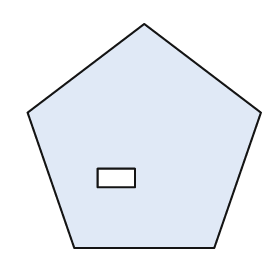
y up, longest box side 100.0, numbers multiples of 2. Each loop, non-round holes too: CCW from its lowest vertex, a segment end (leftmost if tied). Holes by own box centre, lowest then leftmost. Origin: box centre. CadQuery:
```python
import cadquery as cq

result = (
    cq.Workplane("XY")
    .moveTo(-30.0, -48.0)
    .lineTo(30.0, -48.0)
    .lineTo(50.0, 10.0)
    .lineTo(0.0, 48.0)
    .lineTo(-50.0, 10.0)
    .close()
    .moveTo(-20.0, -22.0)
    .lineTo(-4.0, -22.0)
    .lineTo(-4.0, -14.0)
    .lineTo(-20.0, -14.0)
    .close()
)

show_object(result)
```